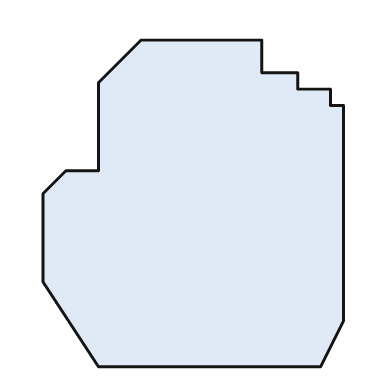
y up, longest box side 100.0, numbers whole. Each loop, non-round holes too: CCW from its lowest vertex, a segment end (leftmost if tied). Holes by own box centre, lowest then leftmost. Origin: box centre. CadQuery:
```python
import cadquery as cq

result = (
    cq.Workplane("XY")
    .moveTo(-29.0, -50.0)
    .lineTo(39.0, -50.0)
    .lineTo(46.0, -36.0)
    .lineTo(46.0, 30.0)
    .lineTo(42.0, 30.0)
    .lineTo(42.0, 35.0)
    .lineTo(32.0, 35.0)
    .lineTo(32.0, 40.0)
    .lineTo(21.0, 40.0)
    .lineTo(21.0, 50.0)
    .lineTo(-16.0, 50.0)
    .lineTo(-29.0, 37.0)
    .lineTo(-29.0, 10.0)
    .lineTo(-39.0, 10.0)
    .lineTo(-46.0, 3.0)
    .lineTo(-46.0, -24.0)
    .close()
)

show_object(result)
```